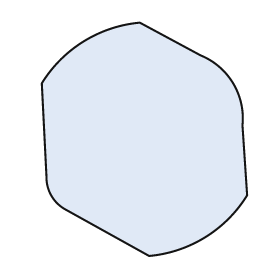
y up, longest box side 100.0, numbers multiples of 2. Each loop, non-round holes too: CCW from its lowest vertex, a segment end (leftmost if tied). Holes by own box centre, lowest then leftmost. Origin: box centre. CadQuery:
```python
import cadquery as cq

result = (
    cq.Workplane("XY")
    .moveTo(2.0, -50.0)
    .threePointArc((26.0, -42.0), (44.0, -24.0))
    .lineTo(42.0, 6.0)
    .threePointArc((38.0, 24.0), (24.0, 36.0))
    .lineTo(-2.0, 50.0)
    .threePointArc((-26.0, 42.0), (-44.0, 24.0))
    .lineTo(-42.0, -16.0)
    .threePointArc((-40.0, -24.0), (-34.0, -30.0))
    .close()
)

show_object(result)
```